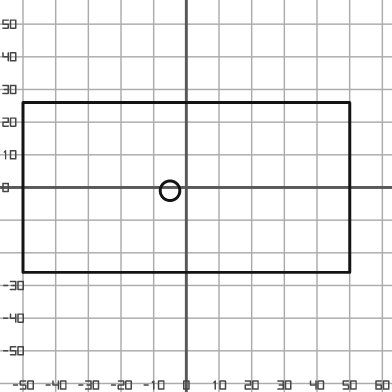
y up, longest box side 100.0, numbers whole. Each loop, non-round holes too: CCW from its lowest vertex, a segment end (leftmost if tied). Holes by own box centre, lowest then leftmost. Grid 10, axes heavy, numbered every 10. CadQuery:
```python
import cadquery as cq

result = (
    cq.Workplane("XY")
    .moveTo(-50.0, -26.0)
    .lineTo(50.0, -26.0)
    .lineTo(50.0, 26.0)
    .lineTo(-50.0, 26.0)
    .close()
    .moveTo(-5.0, -1.0)
    .circle(3.0)
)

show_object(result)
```